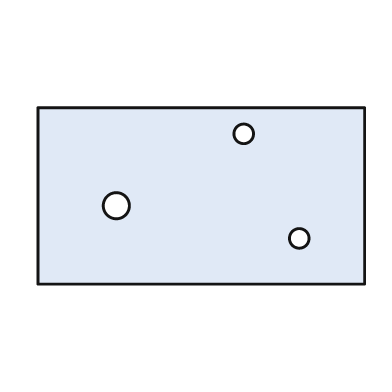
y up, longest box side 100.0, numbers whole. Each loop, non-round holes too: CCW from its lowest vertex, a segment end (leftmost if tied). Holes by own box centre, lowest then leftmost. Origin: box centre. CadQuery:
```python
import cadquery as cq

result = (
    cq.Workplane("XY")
    .moveTo(-50.0, -27.0)
    .lineTo(50.0, -27.0)
    .lineTo(50.0, 27.0)
    .lineTo(-50.0, 27.0)
    .close()
    .moveTo(30.0, -13.0)
    .circle(3.0)
    .moveTo(-26.0, -3.0)
    .circle(4.0)
    .moveTo(13.0, 19.0)
    .circle(3.0)
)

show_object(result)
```